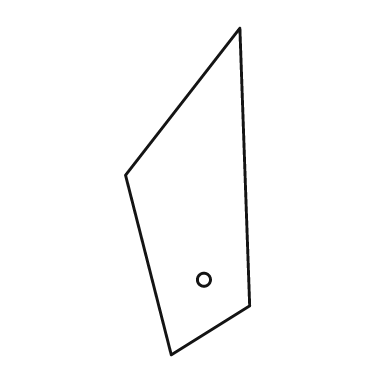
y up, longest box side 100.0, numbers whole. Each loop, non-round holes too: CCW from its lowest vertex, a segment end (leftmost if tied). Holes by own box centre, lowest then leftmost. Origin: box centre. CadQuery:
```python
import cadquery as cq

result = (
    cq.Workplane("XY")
    .moveTo(-5.0, -50.0)
    .lineTo(19.0, -35.0)
    .lineTo(16.0, 50.0)
    .lineTo(-19.0, 5.0)
    .close()
    .moveTo(5.0, -27.0)
    .circle(2.0)
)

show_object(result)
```